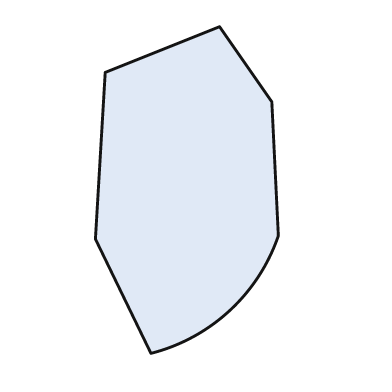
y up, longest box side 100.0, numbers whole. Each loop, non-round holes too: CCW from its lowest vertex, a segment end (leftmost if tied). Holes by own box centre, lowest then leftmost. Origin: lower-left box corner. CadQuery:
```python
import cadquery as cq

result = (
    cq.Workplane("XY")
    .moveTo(17.0, 0.0)
    .threePointArc((41.0, 13.0), (56.0, 36.0))
    .lineTo(54.0, 77.0)
    .lineTo(38.0, 100.0)
    .lineTo(3.0, 86.0)
    .lineTo(0.0, 35.0)
    .close()
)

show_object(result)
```